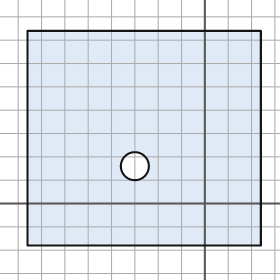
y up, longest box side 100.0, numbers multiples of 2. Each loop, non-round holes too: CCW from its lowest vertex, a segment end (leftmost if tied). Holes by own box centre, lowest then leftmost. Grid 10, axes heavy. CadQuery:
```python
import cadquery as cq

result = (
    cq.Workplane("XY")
    .moveTo(-76.0, -18.0)
    .lineTo(24.0, -18.0)
    .lineTo(24.0, 74.0)
    .lineTo(-76.0, 74.0)
    .close()
    .moveTo(-30.0, 16.0)
    .circle(6.0)
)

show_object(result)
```